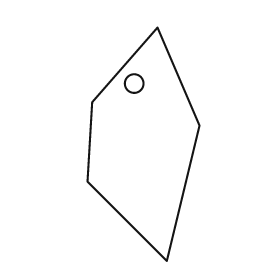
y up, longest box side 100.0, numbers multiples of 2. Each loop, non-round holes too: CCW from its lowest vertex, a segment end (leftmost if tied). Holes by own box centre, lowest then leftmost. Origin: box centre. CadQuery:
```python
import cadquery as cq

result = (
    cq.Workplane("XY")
    .moveTo(10.0, -50.0)
    .lineTo(24.0, 8.0)
    .lineTo(6.0, 50.0)
    .lineTo(-22.0, 18.0)
    .lineTo(-24.0, -16.0)
    .close()
    .moveTo(-4.0, 26.0)
    .circle(4.0)
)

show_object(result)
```